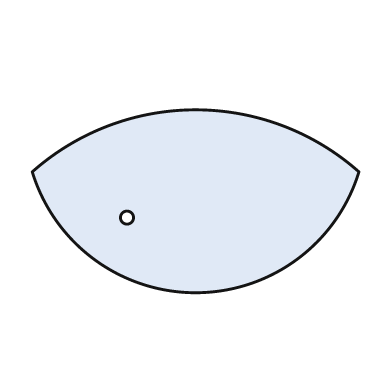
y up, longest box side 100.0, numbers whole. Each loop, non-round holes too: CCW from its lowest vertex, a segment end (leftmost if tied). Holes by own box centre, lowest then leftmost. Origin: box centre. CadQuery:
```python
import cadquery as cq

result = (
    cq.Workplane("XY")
    .moveTo(-50.0, 9.0)
    .threePointArc((0.0, -28.0), (50.0, 9.0))
    .threePointArc((0.0, 28.0), (-50.0, 9.0))
    .close()
    .moveTo(-21.0, -5.0)
    .circle(2.0)
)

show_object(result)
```